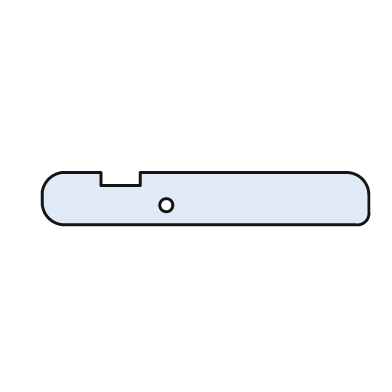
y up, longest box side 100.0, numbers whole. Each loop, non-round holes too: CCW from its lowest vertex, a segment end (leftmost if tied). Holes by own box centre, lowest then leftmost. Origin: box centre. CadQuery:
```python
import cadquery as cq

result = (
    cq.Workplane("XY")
    .moveTo(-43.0, -8.0)
    .lineTo(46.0, -8.0)
    .threePointArc((49.0, -7.0), (50.0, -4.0))
    .lineTo(50.0, 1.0)
    .threePointArc((48.0, 6.0), (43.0, 8.0))
    .lineTo(-20.0, 8.0)
    .lineTo(-20.0, 4.0)
    .lineTo(-32.0, 4.0)
    .lineTo(-32.0, 8.0)
    .lineTo(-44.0, 8.0)
    .threePointArc((-48.0, 6.0), (-50.0, 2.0))
    .lineTo(-50.0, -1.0)
    .threePointArc((-48.0, -6.0), (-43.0, -8.0))
    .close()
    .moveTo(-12.0, -2.0)
    .circle(2.0)
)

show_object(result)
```